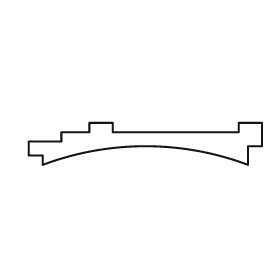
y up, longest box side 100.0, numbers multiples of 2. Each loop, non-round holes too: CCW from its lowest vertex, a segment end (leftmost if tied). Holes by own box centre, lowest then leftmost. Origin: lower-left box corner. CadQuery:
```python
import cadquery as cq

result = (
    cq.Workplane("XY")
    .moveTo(6.0, 0.0)
    .threePointArc((50.0, 8.0), (94.0, 0.0))
    .lineTo(94.0, 8.0)
    .lineTo(100.0, 8.0)
    .lineTo(100.0, 18.0)
    .lineTo(90.0, 18.0)
    .lineTo(90.0, 14.0)
    .lineTo(36.0, 14.0)
    .lineTo(36.0, 18.0)
    .lineTo(26.0, 18.0)
    .lineTo(26.0, 14.0)
    .lineTo(14.0, 14.0)
    .lineTo(14.0, 10.0)
    .lineTo(0.0, 10.0)
    .lineTo(0.0, 4.0)
    .lineTo(6.0, 4.0)
    .close()
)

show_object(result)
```